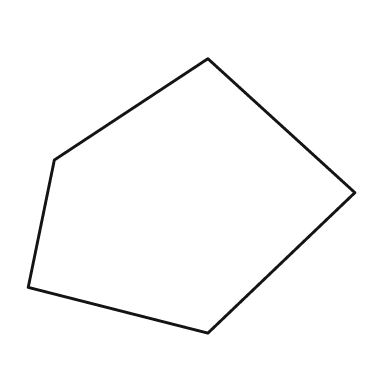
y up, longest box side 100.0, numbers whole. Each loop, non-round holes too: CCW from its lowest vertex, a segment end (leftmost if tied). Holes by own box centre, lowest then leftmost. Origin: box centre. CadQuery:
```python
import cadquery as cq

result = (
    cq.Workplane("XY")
    .moveTo(5.0, -42.0)
    .lineTo(50.0, 1.0)
    .lineTo(5.0, 42.0)
    .lineTo(-42.0, 11.0)
    .lineTo(-50.0, -28.0)
    .close()
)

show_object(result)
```